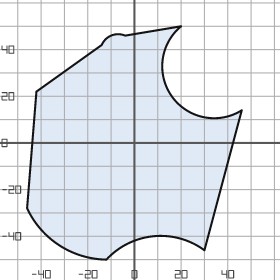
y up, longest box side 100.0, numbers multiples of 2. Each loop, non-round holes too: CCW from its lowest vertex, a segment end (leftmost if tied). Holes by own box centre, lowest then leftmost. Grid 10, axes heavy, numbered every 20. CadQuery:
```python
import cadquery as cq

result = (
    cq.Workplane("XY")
    .moveTo(-12.0, -50.0)
    .threePointArc((8.0, -40.0), (30.0, -46.0))
    .lineTo(46.0, 14.0)
    .threePointArc((16.0, 20.0), (20.0, 50.0))
    .lineTo(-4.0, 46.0)
    .threePointArc((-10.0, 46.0), (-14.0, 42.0))
    .lineTo(-42.0, 22.0)
    .lineTo(-46.0, -28.0)
    .threePointArc((-32.0, -44.0), (-12.0, -50.0))
    .close()
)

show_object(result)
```